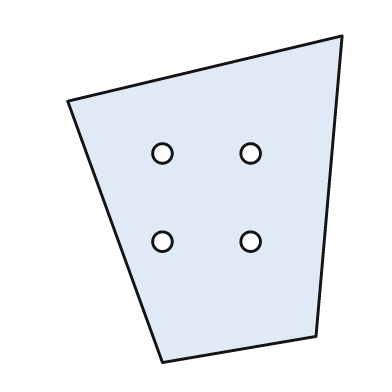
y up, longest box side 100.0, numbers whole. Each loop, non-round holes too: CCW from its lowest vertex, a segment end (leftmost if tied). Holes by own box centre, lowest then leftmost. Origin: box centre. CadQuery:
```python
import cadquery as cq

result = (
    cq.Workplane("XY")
    .moveTo(-13.0, -50.0)
    .lineTo(34.0, -42.0)
    .lineTo(42.0, 50.0)
    .lineTo(-42.0, 30.0)
    .close()
    .moveTo(-13.0, -13.0)
    .circle(3.0)
    .moveTo(14.0, -13.0)
    .circle(3.0)
    .moveTo(-13.0, 14.0)
    .circle(3.0)
    .moveTo(14.0, 14.0)
    .circle(3.0)
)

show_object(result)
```